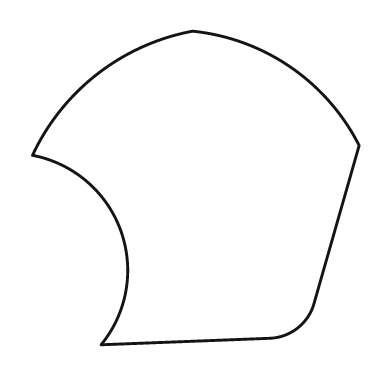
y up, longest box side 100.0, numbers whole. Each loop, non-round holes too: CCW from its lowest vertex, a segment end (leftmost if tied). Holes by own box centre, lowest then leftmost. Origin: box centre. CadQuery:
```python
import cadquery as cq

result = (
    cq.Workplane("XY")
    .moveTo(-29.0, -48.0)
    .lineTo(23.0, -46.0)
    .threePointArc((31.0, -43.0), (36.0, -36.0))
    .lineTo(50.0, 13.0)
    .threePointArc((29.0, 37.0), (-1.0, 48.0))
    .threePointArc((-30.0, 35.0), (-50.0, 10.0))
    .threePointArc((-23.0, -13.0), (-29.0, -48.0))
    .close()
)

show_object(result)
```